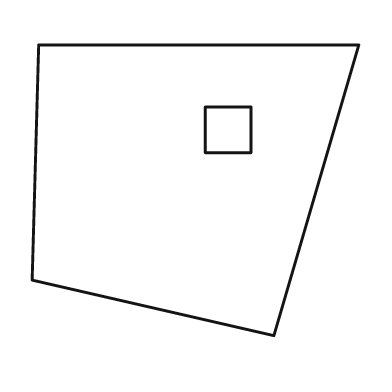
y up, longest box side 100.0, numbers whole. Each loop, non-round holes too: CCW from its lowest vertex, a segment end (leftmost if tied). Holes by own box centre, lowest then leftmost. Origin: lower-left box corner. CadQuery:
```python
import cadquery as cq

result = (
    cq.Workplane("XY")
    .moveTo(74.0, 0.0)
    .lineTo(100.0, 89.0)
    .lineTo(2.0, 89.0)
    .lineTo(0.0, 17.0)
    .close()
    .moveTo(53.0, 56.0)
    .lineTo(67.0, 56.0)
    .lineTo(67.0, 70.0)
    .lineTo(53.0, 70.0)
    .close()
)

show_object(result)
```